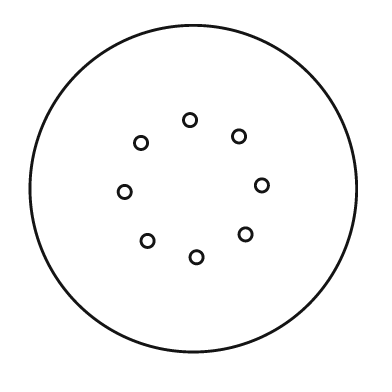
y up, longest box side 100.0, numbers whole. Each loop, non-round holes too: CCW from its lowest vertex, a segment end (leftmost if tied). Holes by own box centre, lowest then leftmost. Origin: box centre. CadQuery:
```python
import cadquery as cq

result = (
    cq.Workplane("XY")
    .moveTo(0.0, 0.0)
    .circle(50.0)
    .moveTo(1.0, -21.0)
    .circle(2.0)
    .moveTo(-14.0, -16.0)
    .circle(2.0)
    .moveTo(16.0, -14.0)
    .circle(2.0)
    .moveTo(-21.0, -1.0)
    .circle(2.0)
    .moveTo(21.0, 1.0)
    .circle(2.0)
    .moveTo(-16.0, 14.0)
    .circle(2.0)
    .moveTo(14.0, 16.0)
    .circle(2.0)
    .moveTo(-1.0, 21.0)
    .circle(2.0)
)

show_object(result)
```